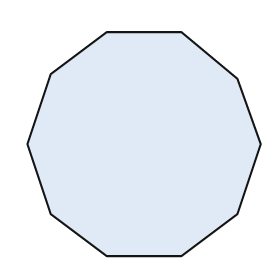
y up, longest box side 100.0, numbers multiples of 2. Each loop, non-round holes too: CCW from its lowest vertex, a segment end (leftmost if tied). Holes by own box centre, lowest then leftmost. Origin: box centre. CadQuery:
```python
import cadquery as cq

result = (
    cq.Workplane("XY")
    .moveTo(-16.0, -48.0)
    .lineTo(16.0, -48.0)
    .lineTo(40.0, -30.0)
    .lineTo(50.0, 0.0)
    .lineTo(40.0, 28.0)
    .lineTo(16.0, 48.0)
    .lineTo(-16.0, 48.0)
    .lineTo(-40.0, 30.0)
    .lineTo(-50.0, 0.0)
    .lineTo(-40.0, -30.0)
    .close()
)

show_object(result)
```